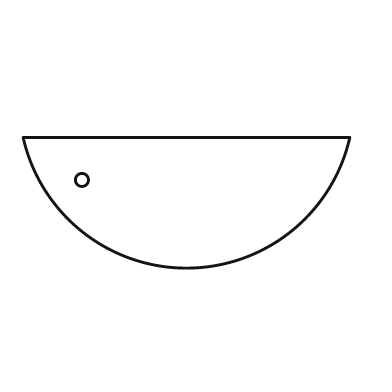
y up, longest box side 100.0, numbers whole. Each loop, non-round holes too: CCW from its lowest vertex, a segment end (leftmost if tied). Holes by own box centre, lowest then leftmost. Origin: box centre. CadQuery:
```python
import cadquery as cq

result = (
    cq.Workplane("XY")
    .moveTo(-50.0, 20.0)
    .threePointArc((0.0, -20.0), (50.0, 20.0))
    .close()
    .moveTo(-32.0, 7.0)
    .circle(2.0)
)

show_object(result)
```